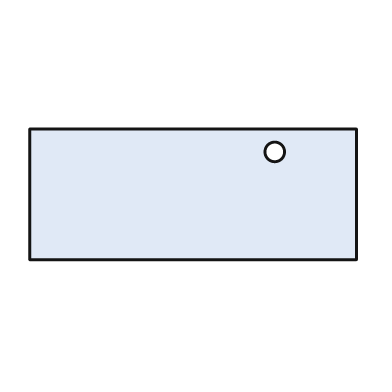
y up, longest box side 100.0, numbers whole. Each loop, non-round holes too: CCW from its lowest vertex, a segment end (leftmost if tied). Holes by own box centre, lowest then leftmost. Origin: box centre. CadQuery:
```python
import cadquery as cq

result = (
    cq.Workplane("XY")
    .moveTo(-50.0, -20.0)
    .lineTo(50.0, -20.0)
    .lineTo(50.0, 20.0)
    .lineTo(-50.0, 20.0)
    .close()
    .moveTo(25.0, 13.0)
    .circle(3.0)
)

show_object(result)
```